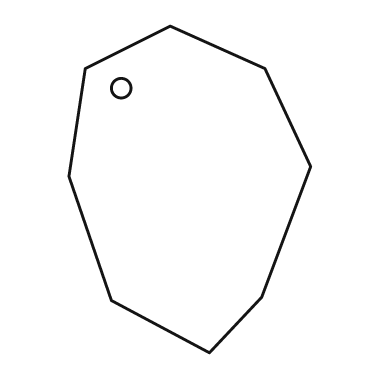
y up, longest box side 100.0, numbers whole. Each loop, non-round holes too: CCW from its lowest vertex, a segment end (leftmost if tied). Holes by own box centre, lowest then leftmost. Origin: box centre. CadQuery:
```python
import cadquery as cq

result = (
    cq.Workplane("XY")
    .moveTo(6.0, -50.0)
    .lineTo(22.0, -33.0)
    .lineTo(37.0, 7.0)
    .lineTo(23.0, 37.0)
    .lineTo(-6.0, 50.0)
    .lineTo(-32.0, 37.0)
    .lineTo(-37.0, 4.0)
    .lineTo(-24.0, -34.0)
    .close()
    .moveTo(-21.0, 31.0)
    .circle(3.0)
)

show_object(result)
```